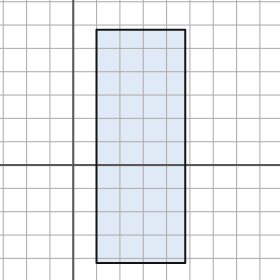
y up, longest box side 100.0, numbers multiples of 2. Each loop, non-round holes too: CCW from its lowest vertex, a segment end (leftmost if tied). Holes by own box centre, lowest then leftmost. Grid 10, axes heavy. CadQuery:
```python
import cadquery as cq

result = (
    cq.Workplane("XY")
    .moveTo(10.0, -42.0)
    .lineTo(48.0, -42.0)
    .lineTo(48.0, 58.0)
    .lineTo(10.0, 58.0)
    .close()
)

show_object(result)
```